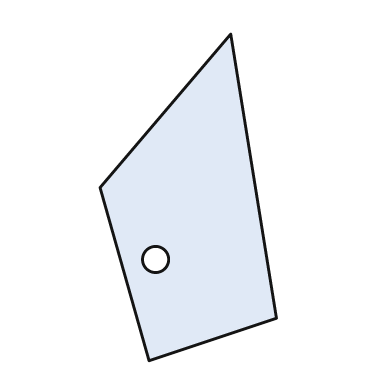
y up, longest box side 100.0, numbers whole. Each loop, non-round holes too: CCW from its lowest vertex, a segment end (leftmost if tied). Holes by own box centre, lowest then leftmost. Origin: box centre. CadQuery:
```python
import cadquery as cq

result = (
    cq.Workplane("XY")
    .moveTo(-12.0, -50.0)
    .lineTo(27.0, -37.0)
    .lineTo(13.0, 50.0)
    .lineTo(-27.0, 3.0)
    .close()
    .moveTo(-10.0, -19.0)
    .circle(4.0)
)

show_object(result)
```